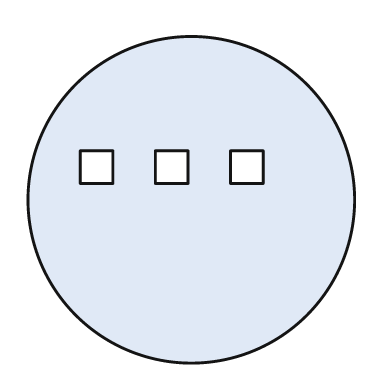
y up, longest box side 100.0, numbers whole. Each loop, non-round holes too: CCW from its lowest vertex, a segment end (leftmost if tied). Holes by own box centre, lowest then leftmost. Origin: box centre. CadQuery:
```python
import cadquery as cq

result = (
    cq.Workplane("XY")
    .moveTo(0.0, 0.0)
    .circle(50.0)
    .moveTo(-34.0, 5.0)
    .lineTo(-24.0, 5.0)
    .lineTo(-24.0, 15.0)
    .lineTo(-34.0, 15.0)
    .close()
    .moveTo(-11.0, 5.0)
    .lineTo(-1.0, 5.0)
    .lineTo(-1.0, 15.0)
    .lineTo(-11.0, 15.0)
    .close()
    .moveTo(12.0, 5.0)
    .lineTo(22.0, 5.0)
    .lineTo(22.0, 15.0)
    .lineTo(12.0, 15.0)
    .close()
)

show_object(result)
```